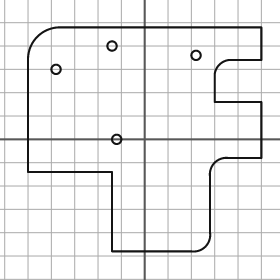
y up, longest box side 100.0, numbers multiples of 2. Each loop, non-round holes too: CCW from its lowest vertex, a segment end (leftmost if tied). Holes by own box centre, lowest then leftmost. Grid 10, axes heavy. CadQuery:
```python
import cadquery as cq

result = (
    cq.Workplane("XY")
    .moveTo(-14.0, -48.0)
    .lineTo(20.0, -48.0)
    .threePointArc((26.0, -46.0), (28.0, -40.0))
    .lineTo(28.0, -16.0)
    .threePointArc((30.0, -10.0), (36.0, -8.0))
    .lineTo(50.0, -8.0)
    .lineTo(50.0, 16.0)
    .lineTo(30.0, 16.0)
    .lineTo(30.0, 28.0)
    .threePointArc((32.0, 32.0), (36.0, 34.0))
    .lineTo(50.0, 34.0)
    .lineTo(50.0, 48.0)
    .lineTo(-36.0, 48.0)
    .threePointArc((-46.0, 44.0), (-50.0, 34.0))
    .lineTo(-50.0, -14.0)
    .lineTo(-14.0, -14.0)
    .close()
    .moveTo(-12.0, 0.0)
    .circle(2.0)
    .moveTo(-38.0, 30.0)
    .circle(2.0)
    .moveTo(22.0, 36.0)
    .circle(2.0)
    .moveTo(-14.0, 40.0)
    .circle(2.0)
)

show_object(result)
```